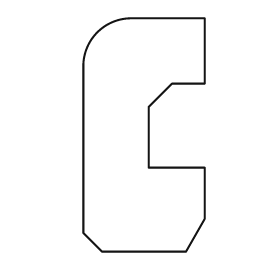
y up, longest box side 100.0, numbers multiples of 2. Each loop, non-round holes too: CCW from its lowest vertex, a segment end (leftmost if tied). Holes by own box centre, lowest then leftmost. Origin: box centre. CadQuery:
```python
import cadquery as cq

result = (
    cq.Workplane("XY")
    .moveTo(-18.0, -50.0)
    .lineTo(18.0, -50.0)
    .lineTo(26.0, -36.0)
    .lineTo(26.0, -14.0)
    .lineTo(2.0, -14.0)
    .lineTo(2.0, 12.0)
    .lineTo(12.0, 22.0)
    .lineTo(26.0, 22.0)
    .lineTo(26.0, 50.0)
    .lineTo(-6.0, 50.0)
    .threePointArc((-20.0, 44.0), (-26.0, 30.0))
    .lineTo(-26.0, -42.0)
    .close()
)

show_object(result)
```